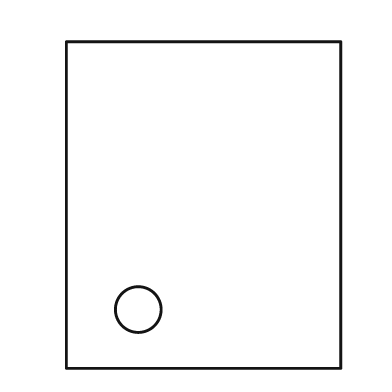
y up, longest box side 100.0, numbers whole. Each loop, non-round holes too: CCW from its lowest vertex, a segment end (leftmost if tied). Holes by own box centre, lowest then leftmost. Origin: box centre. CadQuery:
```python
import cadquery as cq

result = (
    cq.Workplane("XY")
    .moveTo(-42.0, -50.0)
    .lineTo(42.0, -50.0)
    .lineTo(42.0, 50.0)
    .lineTo(-42.0, 50.0)
    .close()
    .moveTo(-20.0, -32.0)
    .circle(7.0)
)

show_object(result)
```